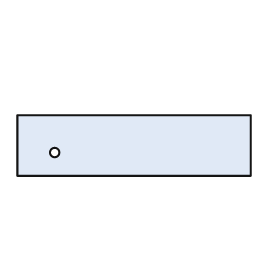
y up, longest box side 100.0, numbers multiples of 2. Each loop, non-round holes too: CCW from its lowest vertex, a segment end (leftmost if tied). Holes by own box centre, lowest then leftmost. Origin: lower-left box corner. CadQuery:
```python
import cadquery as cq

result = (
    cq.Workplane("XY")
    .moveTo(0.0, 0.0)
    .lineTo(100.0, 0.0)
    .lineTo(100.0, 26.0)
    .lineTo(0.0, 26.0)
    .close()
    .moveTo(16.0, 10.0)
    .circle(2.0)
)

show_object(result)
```